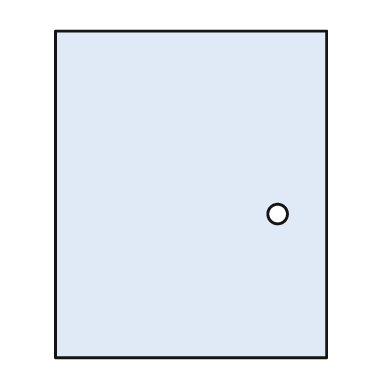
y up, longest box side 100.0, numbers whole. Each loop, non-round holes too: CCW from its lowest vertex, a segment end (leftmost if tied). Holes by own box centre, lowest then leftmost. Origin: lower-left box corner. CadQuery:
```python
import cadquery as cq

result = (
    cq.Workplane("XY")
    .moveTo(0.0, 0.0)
    .lineTo(83.0, 0.0)
    .lineTo(83.0, 100.0)
    .lineTo(0.0, 100.0)
    .close()
    .moveTo(68.0, 44.0)
    .circle(3.0)
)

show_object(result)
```